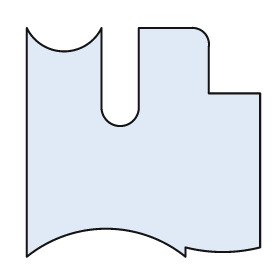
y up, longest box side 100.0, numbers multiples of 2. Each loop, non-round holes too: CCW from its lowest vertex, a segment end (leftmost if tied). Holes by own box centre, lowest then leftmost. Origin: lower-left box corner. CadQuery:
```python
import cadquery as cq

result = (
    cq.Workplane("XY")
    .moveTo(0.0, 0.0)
    .threePointArc((34.0, 12.0), (68.0, 0.0))
    .lineTo(68.0, 4.0)
    .threePointArc((84.0, 2.0), (100.0, 4.0))
    .lineTo(100.0, 70.0)
    .lineTo(78.0, 70.0)
    .lineTo(78.0, 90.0)
    .threePointArc((76.0, 96.0), (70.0, 98.0))
    .lineTo(48.0, 98.0)
    .lineTo(48.0, 64.0)
    .threePointArc((40.0, 56.0), (32.0, 64.0))
    .lineTo(32.0, 98.0)
    .threePointArc((16.0, 88.0), (0.0, 98.0))
    .close()
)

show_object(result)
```